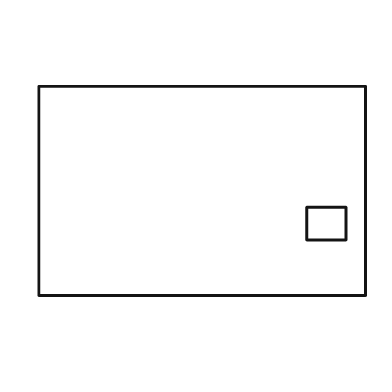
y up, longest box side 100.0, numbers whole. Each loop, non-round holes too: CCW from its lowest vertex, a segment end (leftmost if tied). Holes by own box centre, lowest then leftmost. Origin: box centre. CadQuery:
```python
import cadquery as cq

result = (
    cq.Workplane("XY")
    .moveTo(-50.0, -32.0)
    .lineTo(50.0, -32.0)
    .lineTo(50.0, 32.0)
    .lineTo(-50.0, 32.0)
    .close()
    .moveTo(32.0, -15.0)
    .lineTo(44.0, -15.0)
    .lineTo(44.0, -5.0)
    .lineTo(32.0, -5.0)
    .close()
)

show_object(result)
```